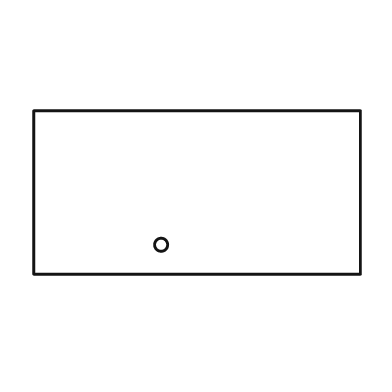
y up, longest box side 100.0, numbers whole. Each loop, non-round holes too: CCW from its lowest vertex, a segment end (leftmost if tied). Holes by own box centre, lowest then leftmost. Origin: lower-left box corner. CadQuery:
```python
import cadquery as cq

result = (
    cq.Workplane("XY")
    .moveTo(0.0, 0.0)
    .lineTo(100.0, 0.0)
    .lineTo(100.0, 50.0)
    .lineTo(0.0, 50.0)
    .close()
    .moveTo(39.0, 9.0)
    .circle(2.0)
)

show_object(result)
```